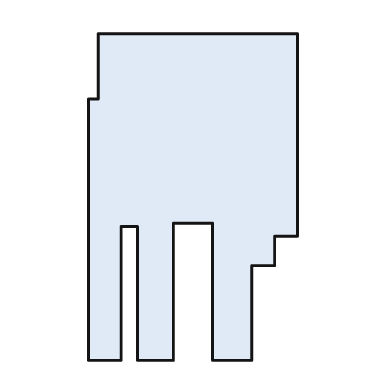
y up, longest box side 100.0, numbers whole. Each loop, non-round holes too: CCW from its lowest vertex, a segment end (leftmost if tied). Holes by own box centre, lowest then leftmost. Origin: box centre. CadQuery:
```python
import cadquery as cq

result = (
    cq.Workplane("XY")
    .moveTo(-32.0, -50.0)
    .lineTo(-22.0, -50.0)
    .lineTo(-22.0, -9.0)
    .lineTo(-17.0, -9.0)
    .lineTo(-17.0, -50.0)
    .lineTo(-6.0, -50.0)
    .lineTo(-6.0, -8.0)
    .lineTo(6.0, -8.0)
    .lineTo(6.0, -50.0)
    .lineTo(18.0, -50.0)
    .lineTo(18.0, -21.0)
    .lineTo(25.0, -21.0)
    .lineTo(25.0, -12.0)
    .lineTo(32.0, -12.0)
    .lineTo(32.0, 50.0)
    .lineTo(-29.0, 50.0)
    .lineTo(-29.0, 30.0)
    .lineTo(-32.0, 30.0)
    .close()
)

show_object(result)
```